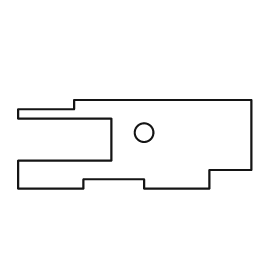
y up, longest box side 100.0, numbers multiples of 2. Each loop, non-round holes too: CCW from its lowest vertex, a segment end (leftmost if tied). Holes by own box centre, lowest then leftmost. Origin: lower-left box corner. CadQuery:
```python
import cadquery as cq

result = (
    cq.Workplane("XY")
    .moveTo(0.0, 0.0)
    .lineTo(28.0, 0.0)
    .lineTo(28.0, 4.0)
    .lineTo(54.0, 4.0)
    .lineTo(54.0, 0.0)
    .lineTo(82.0, 0.0)
    .lineTo(82.0, 8.0)
    .lineTo(100.0, 8.0)
    .lineTo(100.0, 38.0)
    .lineTo(24.0, 38.0)
    .lineTo(24.0, 34.0)
    .lineTo(0.0, 34.0)
    .lineTo(0.0, 30.0)
    .lineTo(40.0, 30.0)
    .lineTo(40.0, 12.0)
    .lineTo(0.0, 12.0)
    .close()
    .moveTo(54.0, 24.0)
    .circle(4.0)
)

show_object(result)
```